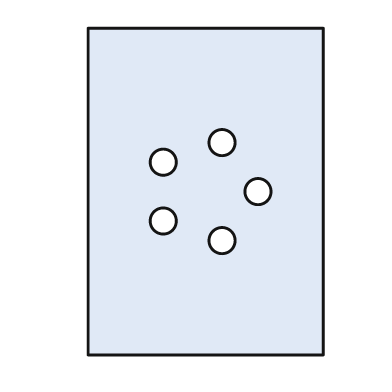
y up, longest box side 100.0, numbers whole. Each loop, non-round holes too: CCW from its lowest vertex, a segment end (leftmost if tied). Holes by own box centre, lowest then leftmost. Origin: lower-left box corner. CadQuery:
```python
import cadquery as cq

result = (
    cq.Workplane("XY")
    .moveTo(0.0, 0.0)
    .lineTo(72.0, 0.0)
    .lineTo(72.0, 100.0)
    .lineTo(0.0, 100.0)
    .close()
    .moveTo(41.0, 35.0)
    .circle(4.0)
    .moveTo(23.0, 41.0)
    .circle(4.0)
    .moveTo(52.0, 50.0)
    .circle(4.0)
    .moveTo(23.0, 59.0)
    .circle(4.0)
    .moveTo(41.0, 65.0)
    .circle(4.0)
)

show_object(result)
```